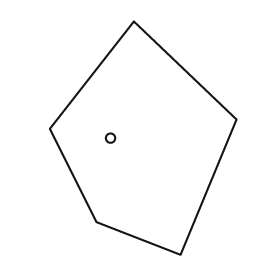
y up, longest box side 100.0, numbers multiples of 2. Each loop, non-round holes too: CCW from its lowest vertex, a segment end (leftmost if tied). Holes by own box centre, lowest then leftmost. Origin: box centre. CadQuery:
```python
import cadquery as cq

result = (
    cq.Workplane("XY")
    .moveTo(16.0, -50.0)
    .lineTo(40.0, 8.0)
    .lineTo(-4.0, 50.0)
    .lineTo(-40.0, 4.0)
    .lineTo(-20.0, -36.0)
    .close()
    .moveTo(-14.0, 0.0)
    .circle(2.0)
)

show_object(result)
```